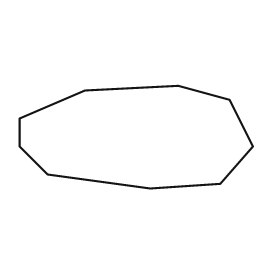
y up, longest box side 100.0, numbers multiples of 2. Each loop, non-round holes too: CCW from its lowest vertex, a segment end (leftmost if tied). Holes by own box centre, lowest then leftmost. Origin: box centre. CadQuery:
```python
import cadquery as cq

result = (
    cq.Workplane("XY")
    .moveTo(6.0, -22.0)
    .lineTo(36.0, -20.0)
    .lineTo(50.0, -4.0)
    .lineTo(40.0, 16.0)
    .lineTo(18.0, 22.0)
    .lineTo(-22.0, 20.0)
    .lineTo(-50.0, 8.0)
    .lineTo(-50.0, -4.0)
    .lineTo(-38.0, -16.0)
    .close()
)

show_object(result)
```